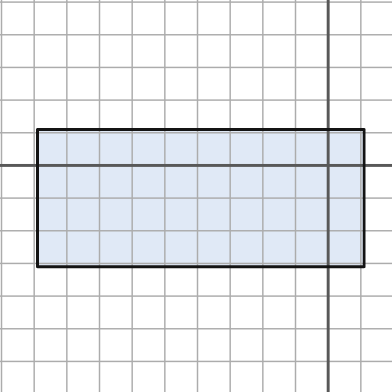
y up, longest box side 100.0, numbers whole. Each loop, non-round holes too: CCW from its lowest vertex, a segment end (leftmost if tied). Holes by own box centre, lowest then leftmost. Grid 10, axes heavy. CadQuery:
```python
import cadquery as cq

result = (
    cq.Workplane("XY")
    .moveTo(-89.0, -31.0)
    .lineTo(11.0, -31.0)
    .lineTo(11.0, 11.0)
    .lineTo(-89.0, 11.0)
    .close()
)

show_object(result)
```